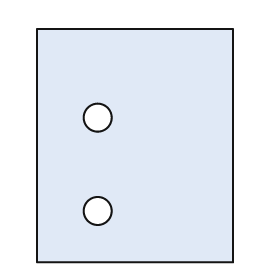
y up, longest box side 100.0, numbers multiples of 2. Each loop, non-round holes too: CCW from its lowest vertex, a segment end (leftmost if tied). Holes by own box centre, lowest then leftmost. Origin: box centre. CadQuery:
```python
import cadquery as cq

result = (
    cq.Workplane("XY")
    .moveTo(-42.0, -50.0)
    .lineTo(42.0, -50.0)
    .lineTo(42.0, 50.0)
    .lineTo(-42.0, 50.0)
    .close()
    .moveTo(-16.0, -28.0)
    .circle(6.0)
    .moveTo(-16.0, 12.0)
    .circle(6.0)
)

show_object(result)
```